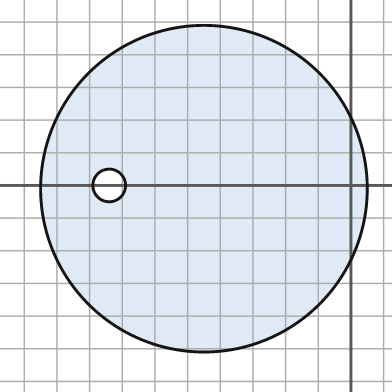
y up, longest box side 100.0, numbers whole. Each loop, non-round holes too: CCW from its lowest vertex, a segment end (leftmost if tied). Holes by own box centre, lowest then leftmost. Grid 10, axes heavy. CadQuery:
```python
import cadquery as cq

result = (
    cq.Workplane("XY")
    .moveTo(-45.0, -1.0)
    .circle(50.0)
    .moveTo(-74.0, 0.0)
    .circle(5.0)
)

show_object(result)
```